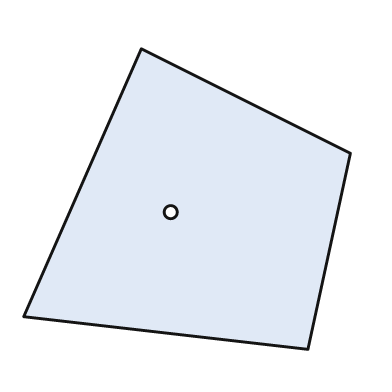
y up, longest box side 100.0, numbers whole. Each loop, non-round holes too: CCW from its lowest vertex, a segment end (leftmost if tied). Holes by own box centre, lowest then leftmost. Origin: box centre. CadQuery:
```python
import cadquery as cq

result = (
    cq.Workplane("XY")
    .moveTo(37.0, -46.0)
    .lineTo(50.0, 14.0)
    .lineTo(-14.0, 46.0)
    .lineTo(-50.0, -36.0)
    .close()
    .moveTo(-5.0, -4.0)
    .circle(2.0)
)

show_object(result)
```